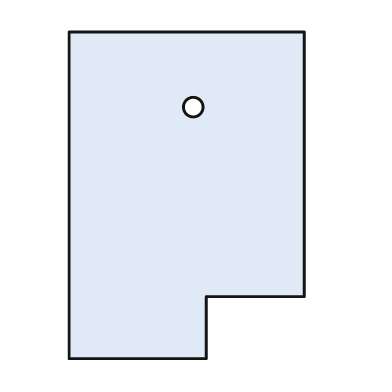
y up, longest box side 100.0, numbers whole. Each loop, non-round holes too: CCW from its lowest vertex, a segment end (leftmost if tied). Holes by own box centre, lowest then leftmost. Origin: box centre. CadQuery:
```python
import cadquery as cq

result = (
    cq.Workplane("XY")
    .moveTo(-36.0, -50.0)
    .lineTo(6.0, -50.0)
    .lineTo(6.0, -31.0)
    .lineTo(36.0, -31.0)
    .lineTo(36.0, 50.0)
    .lineTo(-36.0, 50.0)
    .close()
    .moveTo(2.0, 27.0)
    .circle(3.0)
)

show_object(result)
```